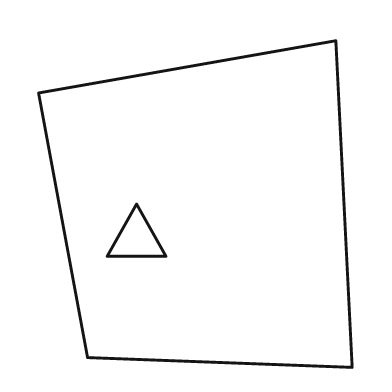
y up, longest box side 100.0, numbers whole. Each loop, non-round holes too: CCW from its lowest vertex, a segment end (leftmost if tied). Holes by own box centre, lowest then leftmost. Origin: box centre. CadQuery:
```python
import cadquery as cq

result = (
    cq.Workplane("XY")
    .moveTo(48.0, -50.0)
    .lineTo(43.0, 50.0)
    .lineTo(-48.0, 34.0)
    .lineTo(-33.0, -47.0)
    .close()
    .moveTo(-27.0, -16.0)
    .lineTo(-9.0, -16.0)
    .lineTo(-18.0, 0.0)
    .close()
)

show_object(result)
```